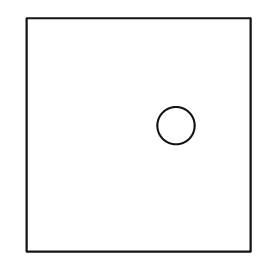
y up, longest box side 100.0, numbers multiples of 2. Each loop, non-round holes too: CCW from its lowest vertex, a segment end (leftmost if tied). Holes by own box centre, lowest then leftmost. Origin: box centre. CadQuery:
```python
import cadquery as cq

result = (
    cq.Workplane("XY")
    .moveTo(-48.0, -50.0)
    .lineTo(48.0, -50.0)
    .lineTo(48.0, 50.0)
    .lineTo(-48.0, 50.0)
    .close()
    .moveTo(16.0, 4.0)
    .circle(8.0)
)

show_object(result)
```